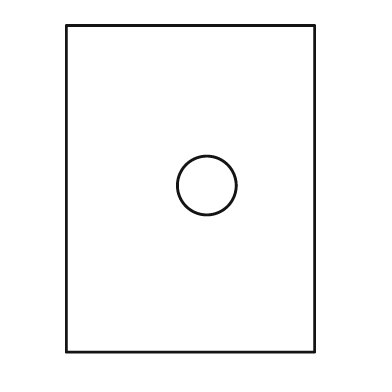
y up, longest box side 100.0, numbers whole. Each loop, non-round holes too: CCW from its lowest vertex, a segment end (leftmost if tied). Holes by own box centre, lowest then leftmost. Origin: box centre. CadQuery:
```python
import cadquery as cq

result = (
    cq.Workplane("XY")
    .moveTo(-38.0, -50.0)
    .lineTo(38.0, -50.0)
    .lineTo(38.0, 50.0)
    .lineTo(-38.0, 50.0)
    .close()
    .moveTo(5.0, 1.0)
    .circle(9.0)
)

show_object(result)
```